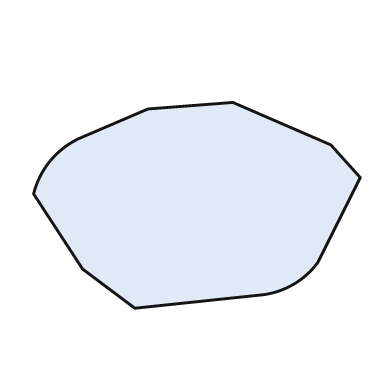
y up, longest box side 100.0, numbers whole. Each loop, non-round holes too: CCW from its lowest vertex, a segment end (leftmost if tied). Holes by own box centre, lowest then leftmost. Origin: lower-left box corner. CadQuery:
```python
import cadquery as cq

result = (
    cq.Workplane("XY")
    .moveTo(31.0, 0.0)
    .lineTo(69.0, 4.0)
    .threePointArc((79.0, 7.0), (87.0, 14.0))
    .lineTo(100.0, 40.0)
    .lineTo(91.0, 50.0)
    .lineTo(61.0, 63.0)
    .lineTo(35.0, 61.0)
    .lineTo(14.0, 52.0)
    .threePointArc((5.0, 45.0), (0.0, 35.0))
    .lineTo(15.0, 12.0)
    .close()
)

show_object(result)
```